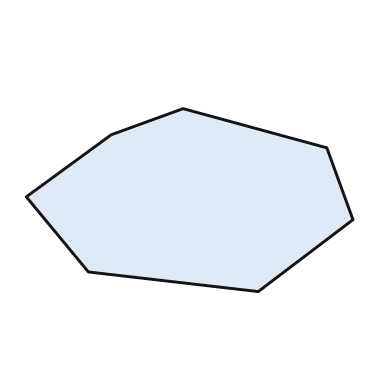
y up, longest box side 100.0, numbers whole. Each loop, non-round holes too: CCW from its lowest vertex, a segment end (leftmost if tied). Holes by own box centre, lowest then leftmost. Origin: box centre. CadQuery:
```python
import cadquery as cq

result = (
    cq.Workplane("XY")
    .moveTo(21.0, -28.0)
    .lineTo(50.0, -6.0)
    .lineTo(42.0, 16.0)
    .lineTo(-2.0, 28.0)
    .lineTo(-24.0, 20.0)
    .lineTo(-50.0, 1.0)
    .lineTo(-31.0, -22.0)
    .close()
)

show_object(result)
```